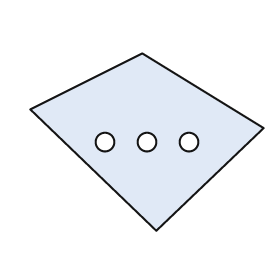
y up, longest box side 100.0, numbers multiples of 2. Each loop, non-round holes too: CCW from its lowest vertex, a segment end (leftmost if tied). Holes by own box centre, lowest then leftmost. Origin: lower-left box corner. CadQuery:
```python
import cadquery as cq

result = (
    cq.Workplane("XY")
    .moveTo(54.0, 0.0)
    .lineTo(100.0, 44.0)
    .lineTo(48.0, 76.0)
    .lineTo(0.0, 52.0)
    .close()
    .moveTo(32.0, 38.0)
    .circle(4.0)
    .moveTo(50.0, 38.0)
    .circle(4.0)
    .moveTo(68.0, 38.0)
    .circle(4.0)
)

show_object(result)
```